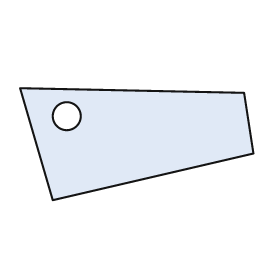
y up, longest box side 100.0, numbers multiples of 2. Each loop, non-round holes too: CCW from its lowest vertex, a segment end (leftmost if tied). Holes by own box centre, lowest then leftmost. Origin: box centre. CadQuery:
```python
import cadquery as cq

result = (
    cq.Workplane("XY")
    .moveTo(-36.0, -24.0)
    .lineTo(50.0, -4.0)
    .lineTo(46.0, 22.0)
    .lineTo(-50.0, 24.0)
    .close()
    .moveTo(-30.0, 12.0)
    .circle(6.0)
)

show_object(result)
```